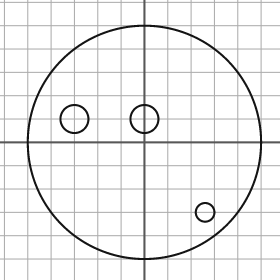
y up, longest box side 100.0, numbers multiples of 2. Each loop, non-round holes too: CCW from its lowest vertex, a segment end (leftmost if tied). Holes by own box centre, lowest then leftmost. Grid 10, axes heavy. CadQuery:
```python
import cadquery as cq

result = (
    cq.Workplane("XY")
    .moveTo(0.0, 0.0)
    .circle(50.0)
    .moveTo(26.0, -30.0)
    .circle(4.0)
    .moveTo(-30.0, 10.0)
    .circle(6.0)
    .moveTo(0.0, 10.0)
    .circle(6.0)
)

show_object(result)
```